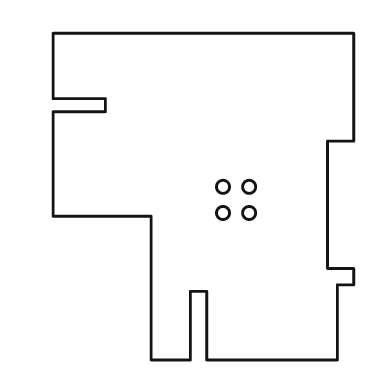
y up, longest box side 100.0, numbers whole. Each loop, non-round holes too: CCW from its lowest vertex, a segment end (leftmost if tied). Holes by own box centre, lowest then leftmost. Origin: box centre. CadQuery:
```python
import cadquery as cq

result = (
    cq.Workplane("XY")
    .moveTo(-16.0, -50.0)
    .lineTo(-4.0, -50.0)
    .lineTo(-4.0, -29.0)
    .lineTo(1.0, -29.0)
    .lineTo(1.0, -50.0)
    .lineTo(41.0, -50.0)
    .lineTo(41.0, -27.0)
    .lineTo(46.0, -27.0)
    .lineTo(46.0, -22.0)
    .lineTo(38.0, -22.0)
    .lineTo(38.0, 17.0)
    .lineTo(46.0, 17.0)
    .lineTo(46.0, 50.0)
    .lineTo(-46.0, 50.0)
    .lineTo(-46.0, 30.0)
    .lineTo(-30.0, 30.0)
    .lineTo(-30.0, 26.0)
    .lineTo(-46.0, 26.0)
    .lineTo(-46.0, -6.0)
    .lineTo(-16.0, -6.0)
    .close()
    .moveTo(6.0, -5.0)
    .circle(2.0)
    .moveTo(14.0, -5.0)
    .circle(2.0)
    .moveTo(6.0, 3.0)
    .circle(2.0)
    .moveTo(14.0, 3.0)
    .circle(2.0)
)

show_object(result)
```